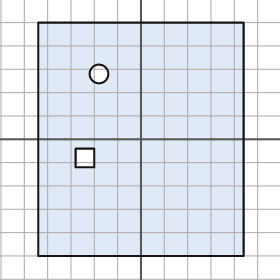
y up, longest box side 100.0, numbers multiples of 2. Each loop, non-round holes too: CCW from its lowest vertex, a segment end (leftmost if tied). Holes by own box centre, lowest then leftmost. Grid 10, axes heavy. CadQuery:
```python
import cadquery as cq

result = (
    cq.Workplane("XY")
    .moveTo(-44.0, -50.0)
    .lineTo(44.0, -50.0)
    .lineTo(44.0, 50.0)
    .lineTo(-44.0, 50.0)
    .close()
    .moveTo(-28.0, -12.0)
    .lineTo(-20.0, -12.0)
    .lineTo(-20.0, -4.0)
    .lineTo(-28.0, -4.0)
    .close()
    .moveTo(-18.0, 28.0)
    .circle(4.0)
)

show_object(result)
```